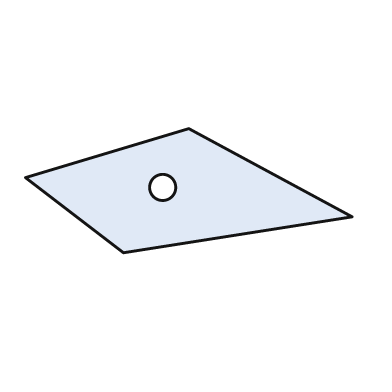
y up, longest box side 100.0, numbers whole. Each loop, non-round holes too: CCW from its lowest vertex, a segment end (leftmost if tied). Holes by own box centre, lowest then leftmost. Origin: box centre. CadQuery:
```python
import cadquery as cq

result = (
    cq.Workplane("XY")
    .moveTo(-20.0, -19.0)
    .lineTo(50.0, -8.0)
    .lineTo(0.0, 19.0)
    .lineTo(-50.0, 4.0)
    .close()
    .moveTo(-8.0, 1.0)
    .circle(4.0)
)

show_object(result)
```